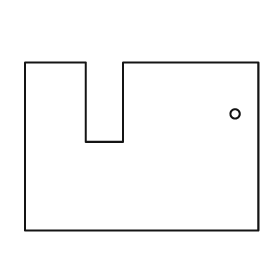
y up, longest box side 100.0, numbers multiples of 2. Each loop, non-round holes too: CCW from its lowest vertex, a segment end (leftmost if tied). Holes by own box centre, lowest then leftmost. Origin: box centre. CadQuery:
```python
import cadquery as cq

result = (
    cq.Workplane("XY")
    .moveTo(-50.0, -36.0)
    .lineTo(50.0, -36.0)
    .lineTo(50.0, 36.0)
    .lineTo(-8.0, 36.0)
    .lineTo(-8.0, 2.0)
    .lineTo(-24.0, 2.0)
    .lineTo(-24.0, 36.0)
    .lineTo(-50.0, 36.0)
    .close()
    .moveTo(40.0, 14.0)
    .circle(2.0)
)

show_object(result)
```